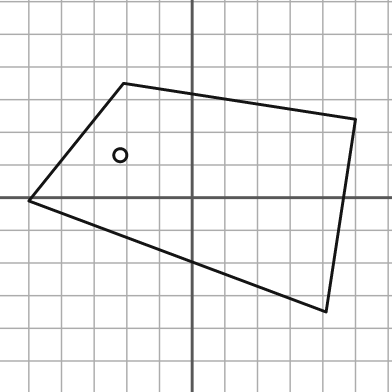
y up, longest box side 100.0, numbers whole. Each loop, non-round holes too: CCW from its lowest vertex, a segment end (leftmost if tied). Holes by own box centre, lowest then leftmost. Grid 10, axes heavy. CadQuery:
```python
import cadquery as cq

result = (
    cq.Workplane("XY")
    .moveTo(41.0, -35.0)
    .lineTo(50.0, 24.0)
    .lineTo(-21.0, 35.0)
    .lineTo(-50.0, -1.0)
    .close()
    .moveTo(-22.0, 13.0)
    .circle(2.0)
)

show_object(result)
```